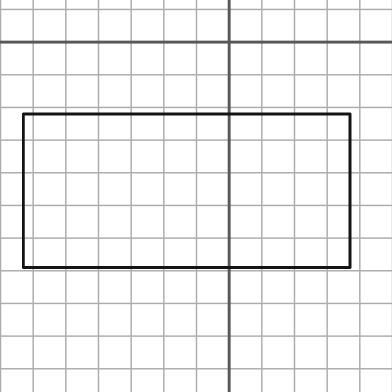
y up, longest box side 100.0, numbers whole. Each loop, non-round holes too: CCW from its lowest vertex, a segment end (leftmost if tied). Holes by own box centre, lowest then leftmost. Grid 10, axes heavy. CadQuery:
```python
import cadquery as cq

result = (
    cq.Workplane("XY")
    .moveTo(-63.0, -69.0)
    .lineTo(37.0, -69.0)
    .lineTo(37.0, -22.0)
    .lineTo(-63.0, -22.0)
    .close()
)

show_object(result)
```